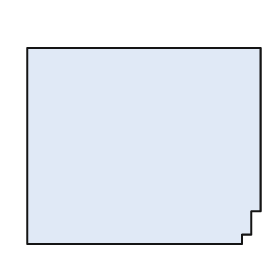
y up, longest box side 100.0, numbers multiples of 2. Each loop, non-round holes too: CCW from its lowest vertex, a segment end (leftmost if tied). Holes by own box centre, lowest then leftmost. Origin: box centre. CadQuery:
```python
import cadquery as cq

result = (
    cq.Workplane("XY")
    .moveTo(-50.0, -42.0)
    .lineTo(42.0, -42.0)
    .lineTo(42.0, -38.0)
    .lineTo(46.0, -38.0)
    .lineTo(46.0, -28.0)
    .lineTo(50.0, -28.0)
    .lineTo(50.0, 42.0)
    .lineTo(-50.0, 42.0)
    .close()
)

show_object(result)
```